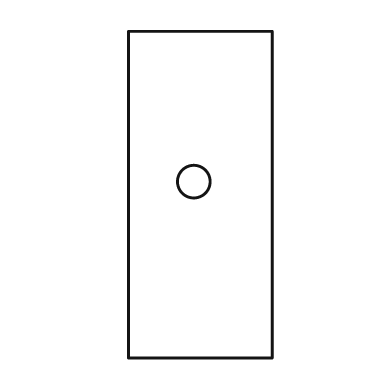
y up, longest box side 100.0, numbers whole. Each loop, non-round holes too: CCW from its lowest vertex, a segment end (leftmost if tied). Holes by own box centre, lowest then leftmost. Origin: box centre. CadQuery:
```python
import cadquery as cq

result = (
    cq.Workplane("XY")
    .moveTo(-22.0, -50.0)
    .lineTo(22.0, -50.0)
    .lineTo(22.0, 50.0)
    .lineTo(-22.0, 50.0)
    .close()
    .moveTo(-2.0, 4.0)
    .circle(5.0)
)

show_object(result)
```